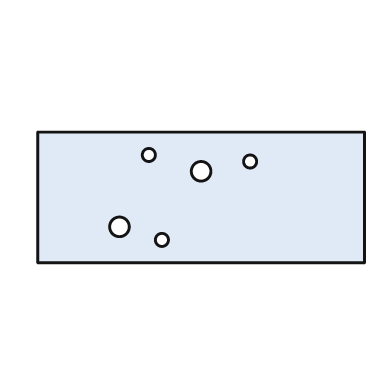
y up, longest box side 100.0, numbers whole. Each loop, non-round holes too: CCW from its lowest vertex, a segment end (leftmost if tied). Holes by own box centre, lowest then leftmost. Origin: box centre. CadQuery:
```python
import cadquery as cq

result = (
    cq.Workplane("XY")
    .moveTo(-50.0, -20.0)
    .lineTo(50.0, -20.0)
    .lineTo(50.0, 20.0)
    .lineTo(-50.0, 20.0)
    .close()
    .moveTo(-12.0, -13.0)
    .circle(2.0)
    .moveTo(-25.0, -9.0)
    .circle(3.0)
    .moveTo(0.0, 8.0)
    .circle(3.0)
    .moveTo(15.0, 11.0)
    .circle(2.0)
    .moveTo(-16.0, 13.0)
    .circle(2.0)
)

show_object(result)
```